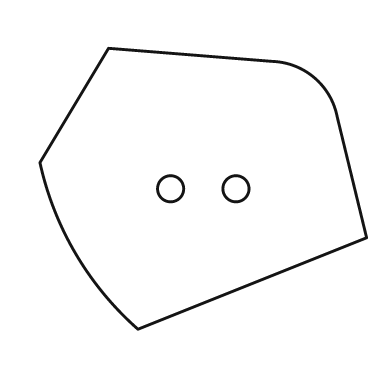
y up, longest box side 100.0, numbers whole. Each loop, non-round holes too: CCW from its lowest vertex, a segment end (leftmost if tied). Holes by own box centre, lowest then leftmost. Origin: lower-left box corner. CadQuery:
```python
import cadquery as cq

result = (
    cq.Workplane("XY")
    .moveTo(30.0, 0.0)
    .lineTo(100.0, 28.0)
    .lineTo(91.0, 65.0)
    .threePointArc((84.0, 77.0), (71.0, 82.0))
    .lineTo(21.0, 86.0)
    .lineTo(0.0, 51.0)
    .threePointArc((11.0, 23.0), (30.0, 0.0))
    .close()
    .moveTo(40.0, 43.0)
    .circle(4.0)
    .moveTo(60.0, 43.0)
    .circle(4.0)
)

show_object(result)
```